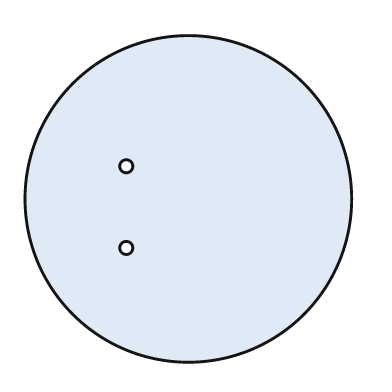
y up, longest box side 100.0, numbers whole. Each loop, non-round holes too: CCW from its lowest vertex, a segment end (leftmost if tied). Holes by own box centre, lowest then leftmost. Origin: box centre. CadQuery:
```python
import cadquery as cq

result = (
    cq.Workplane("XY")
    .moveTo(0.0, 0.0)
    .circle(50.0)
    .moveTo(-19.0, -15.0)
    .circle(2.0)
    .moveTo(-19.0, 10.0)
    .circle(2.0)
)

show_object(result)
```